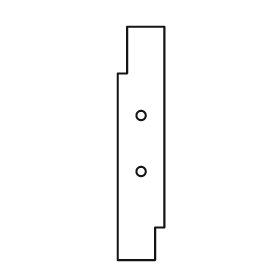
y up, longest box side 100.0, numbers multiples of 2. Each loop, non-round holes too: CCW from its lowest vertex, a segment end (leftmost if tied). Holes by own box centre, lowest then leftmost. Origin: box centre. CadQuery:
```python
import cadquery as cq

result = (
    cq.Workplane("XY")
    .moveTo(-10.0, -50.0)
    .lineTo(6.0, -50.0)
    .lineTo(6.0, -36.0)
    .lineTo(10.0, -36.0)
    .lineTo(10.0, 50.0)
    .lineTo(-6.0, 50.0)
    .lineTo(-6.0, 30.0)
    .lineTo(-10.0, 30.0)
    .close()
    .moveTo(0.0, -12.0)
    .circle(2.0)
    .moveTo(0.0, 12.0)
    .circle(2.0)
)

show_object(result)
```